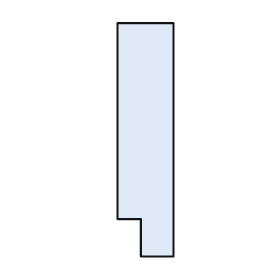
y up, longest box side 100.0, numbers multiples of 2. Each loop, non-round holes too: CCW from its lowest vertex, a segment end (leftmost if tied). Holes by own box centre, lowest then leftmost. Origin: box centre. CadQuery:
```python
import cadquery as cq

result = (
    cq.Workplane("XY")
    .moveTo(-2.0, -50.0)
    .lineTo(12.0, -50.0)
    .lineTo(12.0, 50.0)
    .lineTo(-12.0, 50.0)
    .lineTo(-12.0, -34.0)
    .lineTo(-2.0, -34.0)
    .close()
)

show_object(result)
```